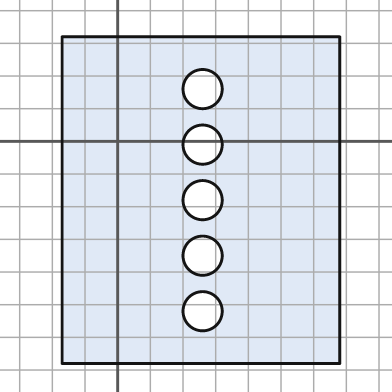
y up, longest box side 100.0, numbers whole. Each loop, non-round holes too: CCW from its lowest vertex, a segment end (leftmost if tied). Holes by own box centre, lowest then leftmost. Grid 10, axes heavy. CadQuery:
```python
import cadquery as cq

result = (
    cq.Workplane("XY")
    .moveTo(-17.0, -68.0)
    .lineTo(68.0, -68.0)
    .lineTo(68.0, 32.0)
    .lineTo(-17.0, 32.0)
    .close()
    .moveTo(26.0, -52.0)
    .circle(6.0)
    .moveTo(26.0, -35.0)
    .circle(6.0)
    .moveTo(26.0, -18.0)
    .circle(6.0)
    .moveTo(26.0, -1.0)
    .circle(6.0)
    .moveTo(26.0, 16.0)
    .circle(6.0)
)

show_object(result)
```